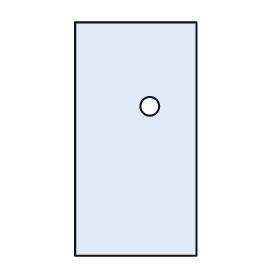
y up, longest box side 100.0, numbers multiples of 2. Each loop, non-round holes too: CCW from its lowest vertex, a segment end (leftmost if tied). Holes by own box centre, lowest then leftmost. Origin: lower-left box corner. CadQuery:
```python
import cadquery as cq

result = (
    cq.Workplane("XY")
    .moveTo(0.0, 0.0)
    .lineTo(52.0, 0.0)
    .lineTo(52.0, 100.0)
    .lineTo(0.0, 100.0)
    .close()
    .moveTo(32.0, 64.0)
    .circle(4.0)
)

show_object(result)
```